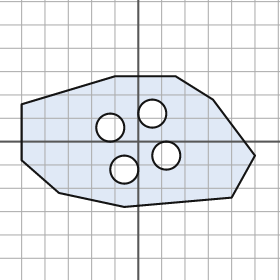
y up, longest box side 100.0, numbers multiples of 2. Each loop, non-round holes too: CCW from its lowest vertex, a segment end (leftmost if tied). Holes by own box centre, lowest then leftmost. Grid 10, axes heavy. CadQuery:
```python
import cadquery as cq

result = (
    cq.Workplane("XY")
    .moveTo(-6.0, -28.0)
    .lineTo(40.0, -24.0)
    .lineTo(50.0, -6.0)
    .lineTo(32.0, 18.0)
    .lineTo(16.0, 28.0)
    .lineTo(-10.0, 28.0)
    .lineTo(-50.0, 16.0)
    .lineTo(-50.0, -8.0)
    .lineTo(-34.0, -22.0)
    .close()
    .moveTo(-6.0, -12.0)
    .circle(6.0)
    .moveTo(12.0, -6.0)
    .circle(6.0)
    .moveTo(-12.0, 6.0)
    .circle(6.0)
    .moveTo(6.0, 12.0)
    .circle(6.0)
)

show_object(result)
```